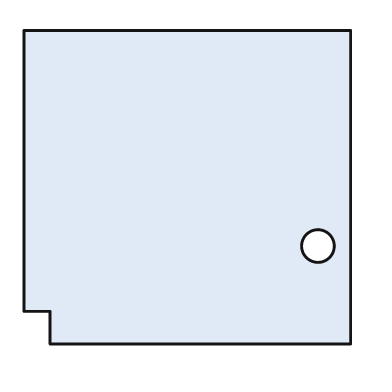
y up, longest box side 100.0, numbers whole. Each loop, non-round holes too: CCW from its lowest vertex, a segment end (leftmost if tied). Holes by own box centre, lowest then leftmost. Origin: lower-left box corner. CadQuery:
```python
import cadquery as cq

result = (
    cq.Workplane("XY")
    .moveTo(8.0, 0.0)
    .lineTo(100.0, 0.0)
    .lineTo(100.0, 96.0)
    .lineTo(0.0, 96.0)
    .lineTo(0.0, 10.0)
    .lineTo(8.0, 10.0)
    .close()
    .moveTo(90.0, 30.0)
    .circle(5.0)
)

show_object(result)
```